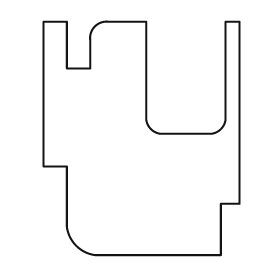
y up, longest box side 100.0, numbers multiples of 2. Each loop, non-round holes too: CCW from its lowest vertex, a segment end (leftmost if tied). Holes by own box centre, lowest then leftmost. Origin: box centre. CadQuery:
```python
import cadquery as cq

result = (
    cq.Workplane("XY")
    .moveTo(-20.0, -50.0)
    .lineTo(34.0, -50.0)
    .lineTo(34.0, -28.0)
    .lineTo(42.0, -28.0)
    .lineTo(42.0, 50.0)
    .lineTo(36.0, 50.0)
    .lineTo(36.0, 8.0)
    .threePointArc((34.0, 4.0), (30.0, 2.0))
    .lineTo(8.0, 2.0)
    .threePointArc((4.0, 4.0), (2.0, 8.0))
    .lineTo(2.0, 50.0)
    .lineTo(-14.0, 50.0)
    .threePointArc((-20.0, 48.0), (-22.0, 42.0))
    .lineTo(-22.0, 30.0)
    .lineTo(-32.0, 30.0)
    .lineTo(-32.0, 50.0)
    .lineTo(-42.0, 50.0)
    .lineTo(-42.0, -12.0)
    .lineTo(-32.0, -12.0)
    .lineTo(-32.0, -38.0)
    .threePointArc((-28.0, -46.0), (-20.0, -50.0))
    .close()
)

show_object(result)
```